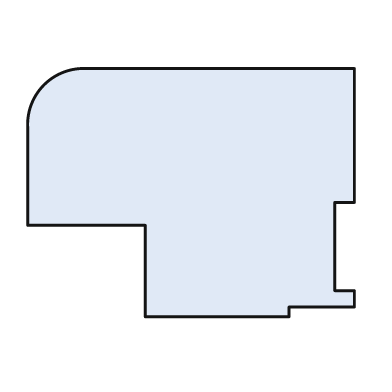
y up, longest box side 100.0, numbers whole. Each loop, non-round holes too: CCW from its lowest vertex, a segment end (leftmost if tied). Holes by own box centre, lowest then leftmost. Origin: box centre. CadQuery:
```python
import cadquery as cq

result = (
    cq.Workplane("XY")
    .moveTo(-14.0, -38.0)
    .lineTo(30.0, -38.0)
    .lineTo(30.0, -35.0)
    .lineTo(50.0, -35.0)
    .lineTo(50.0, -30.0)
    .lineTo(44.0, -30.0)
    .lineTo(44.0, -3.0)
    .lineTo(50.0, -3.0)
    .lineTo(50.0, 38.0)
    .lineTo(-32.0, 38.0)
    .threePointArc((-45.0, 33.0), (-50.0, 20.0))
    .lineTo(-50.0, -10.0)
    .lineTo(-14.0, -10.0)
    .close()
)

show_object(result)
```